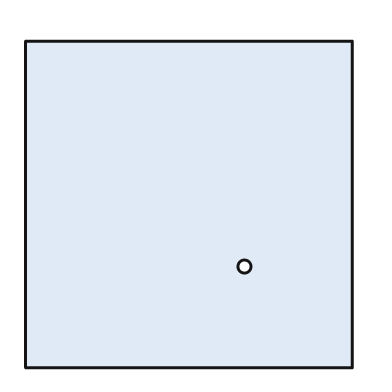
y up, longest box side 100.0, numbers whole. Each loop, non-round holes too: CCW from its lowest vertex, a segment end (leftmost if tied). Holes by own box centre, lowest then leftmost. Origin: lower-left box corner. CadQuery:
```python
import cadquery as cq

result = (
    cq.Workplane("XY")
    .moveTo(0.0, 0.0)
    .lineTo(100.0, 0.0)
    .lineTo(100.0, 100.0)
    .lineTo(0.0, 100.0)
    .close()
    .moveTo(67.0, 31.0)
    .circle(2.0)
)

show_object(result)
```